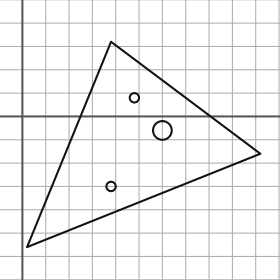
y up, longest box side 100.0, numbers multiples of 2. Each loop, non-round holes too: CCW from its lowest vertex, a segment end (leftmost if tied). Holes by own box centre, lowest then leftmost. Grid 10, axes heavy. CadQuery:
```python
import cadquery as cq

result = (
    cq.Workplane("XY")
    .moveTo(2.0, -56.0)
    .lineTo(102.0, -16.0)
    .lineTo(38.0, 32.0)
    .close()
    .moveTo(38.0, -30.0)
    .circle(2.0)
    .moveTo(60.0, -6.0)
    .circle(4.0)
    .moveTo(48.0, 8.0)
    .circle(2.0)
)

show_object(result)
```